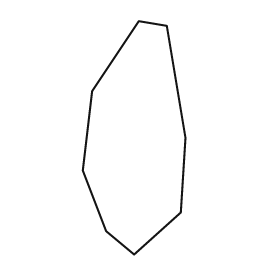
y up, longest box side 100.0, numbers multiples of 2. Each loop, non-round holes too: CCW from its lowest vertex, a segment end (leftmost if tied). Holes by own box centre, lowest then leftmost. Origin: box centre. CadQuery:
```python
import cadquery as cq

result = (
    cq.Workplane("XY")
    .moveTo(0.0, -50.0)
    .lineTo(20.0, -32.0)
    .lineTo(22.0, 0.0)
    .lineTo(14.0, 48.0)
    .lineTo(2.0, 50.0)
    .lineTo(-18.0, 20.0)
    .lineTo(-22.0, -14.0)
    .lineTo(-12.0, -40.0)
    .close()
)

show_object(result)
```